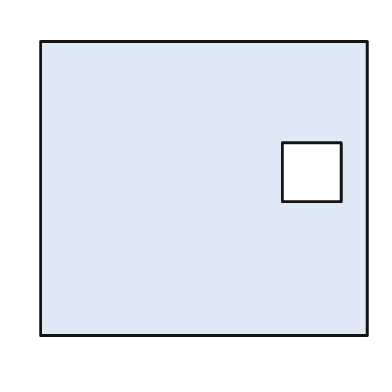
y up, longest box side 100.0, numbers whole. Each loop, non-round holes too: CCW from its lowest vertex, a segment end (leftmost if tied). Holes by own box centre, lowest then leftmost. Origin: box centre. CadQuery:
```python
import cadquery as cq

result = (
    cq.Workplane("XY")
    .moveTo(-50.0, -45.0)
    .lineTo(50.0, -45.0)
    .lineTo(50.0, 45.0)
    .lineTo(-50.0, 45.0)
    .close()
    .moveTo(24.0, -4.0)
    .lineTo(42.0, -4.0)
    .lineTo(42.0, 14.0)
    .lineTo(24.0, 14.0)
    .close()
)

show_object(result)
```